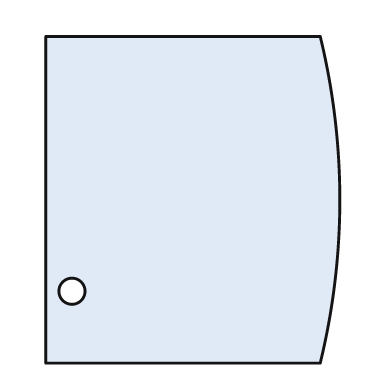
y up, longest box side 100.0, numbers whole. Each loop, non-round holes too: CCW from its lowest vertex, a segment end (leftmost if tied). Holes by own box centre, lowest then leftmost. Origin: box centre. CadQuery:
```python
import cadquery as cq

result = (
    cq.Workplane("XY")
    .moveTo(-45.0, -50.0)
    .lineTo(39.0, -50.0)
    .threePointArc((45.0, 0.0), (39.0, 50.0))
    .lineTo(-45.0, 50.0)
    .close()
    .moveTo(-37.0, -28.0)
    .circle(4.0)
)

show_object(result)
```